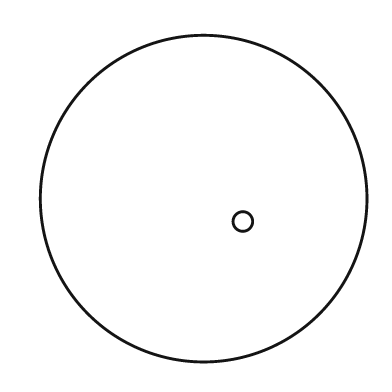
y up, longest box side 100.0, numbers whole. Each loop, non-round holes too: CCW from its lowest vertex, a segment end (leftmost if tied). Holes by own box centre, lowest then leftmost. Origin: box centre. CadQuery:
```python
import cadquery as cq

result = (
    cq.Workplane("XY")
    .moveTo(0.0, 0.0)
    .circle(50.0)
    .moveTo(12.0, -7.0)
    .circle(3.0)
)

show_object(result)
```